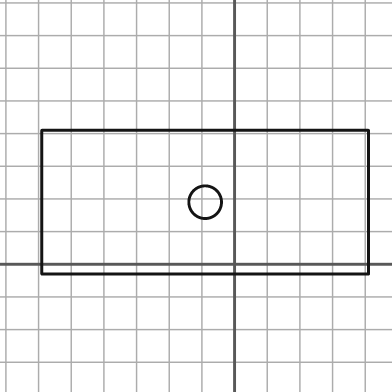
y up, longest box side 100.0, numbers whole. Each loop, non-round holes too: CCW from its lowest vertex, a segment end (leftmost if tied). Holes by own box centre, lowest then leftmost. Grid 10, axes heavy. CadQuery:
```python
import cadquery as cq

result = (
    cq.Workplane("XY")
    .moveTo(-59.0, -3.0)
    .lineTo(41.0, -3.0)
    .lineTo(41.0, 41.0)
    .lineTo(-59.0, 41.0)
    .close()
    .moveTo(-9.0, 19.0)
    .circle(5.0)
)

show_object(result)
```